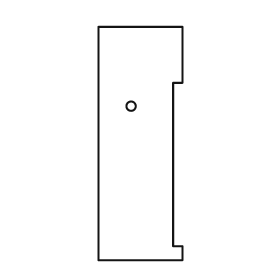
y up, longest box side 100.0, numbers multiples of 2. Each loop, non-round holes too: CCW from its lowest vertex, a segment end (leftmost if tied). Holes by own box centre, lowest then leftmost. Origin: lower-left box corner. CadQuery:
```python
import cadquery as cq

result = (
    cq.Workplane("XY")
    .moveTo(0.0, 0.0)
    .lineTo(36.0, 0.0)
    .lineTo(36.0, 6.0)
    .lineTo(32.0, 6.0)
    .lineTo(32.0, 76.0)
    .lineTo(36.0, 76.0)
    .lineTo(36.0, 100.0)
    .lineTo(0.0, 100.0)
    .close()
    .moveTo(14.0, 66.0)
    .circle(2.0)
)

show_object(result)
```